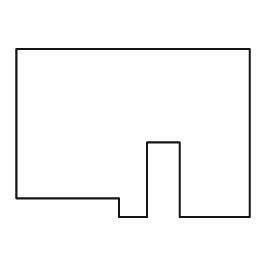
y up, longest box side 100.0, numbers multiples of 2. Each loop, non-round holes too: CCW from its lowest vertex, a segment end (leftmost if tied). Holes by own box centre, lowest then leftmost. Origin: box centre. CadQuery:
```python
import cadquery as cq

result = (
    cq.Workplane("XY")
    .moveTo(-6.0, -36.0)
    .lineTo(6.0, -36.0)
    .lineTo(6.0, -4.0)
    .lineTo(20.0, -4.0)
    .lineTo(20.0, -36.0)
    .lineTo(50.0, -36.0)
    .lineTo(50.0, 36.0)
    .lineTo(-50.0, 36.0)
    .lineTo(-50.0, -28.0)
    .lineTo(-6.0, -28.0)
    .close()
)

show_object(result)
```